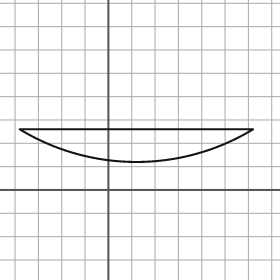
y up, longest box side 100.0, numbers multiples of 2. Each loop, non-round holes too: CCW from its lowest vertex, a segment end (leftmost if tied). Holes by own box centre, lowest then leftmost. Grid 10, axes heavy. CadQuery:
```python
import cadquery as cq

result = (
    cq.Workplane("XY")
    .moveTo(-38.0, 26.0)
    .threePointArc((12.0, 12.0), (62.0, 26.0))
    .close()
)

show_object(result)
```